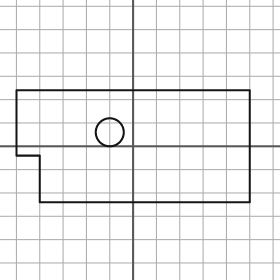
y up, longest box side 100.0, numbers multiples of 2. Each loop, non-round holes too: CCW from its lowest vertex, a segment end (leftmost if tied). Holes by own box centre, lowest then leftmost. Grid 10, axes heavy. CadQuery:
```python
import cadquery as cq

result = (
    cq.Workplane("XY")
    .moveTo(-40.0, -24.0)
    .lineTo(50.0, -24.0)
    .lineTo(50.0, 24.0)
    .lineTo(-50.0, 24.0)
    .lineTo(-50.0, -4.0)
    .lineTo(-40.0, -4.0)
    .close()
    .moveTo(-10.0, 6.0)
    .circle(6.0)
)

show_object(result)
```